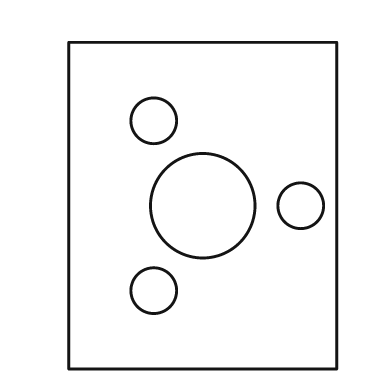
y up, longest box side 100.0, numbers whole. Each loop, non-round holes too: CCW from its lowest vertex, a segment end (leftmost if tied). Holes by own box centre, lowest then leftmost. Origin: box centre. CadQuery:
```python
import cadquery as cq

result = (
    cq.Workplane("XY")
    .moveTo(-41.0, -50.0)
    .lineTo(41.0, -50.0)
    .lineTo(41.0, 50.0)
    .lineTo(-41.0, 50.0)
    .close()
    .moveTo(-15.0, -26.0)
    .circle(7.0)
    .moveTo(0.0, 0.0)
    .circle(16.0)
    .moveTo(30.0, 0.0)
    .circle(7.0)
    .moveTo(-15.0, 26.0)
    .circle(7.0)
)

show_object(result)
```